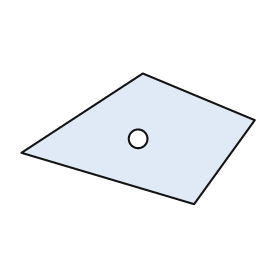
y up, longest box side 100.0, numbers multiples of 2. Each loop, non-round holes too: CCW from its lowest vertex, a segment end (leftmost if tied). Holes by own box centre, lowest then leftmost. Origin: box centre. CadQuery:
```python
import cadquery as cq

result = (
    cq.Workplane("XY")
    .moveTo(24.0, -28.0)
    .lineTo(50.0, 8.0)
    .lineTo(2.0, 28.0)
    .lineTo(-50.0, -6.0)
    .close()
    .moveTo(0.0, 0.0)
    .circle(4.0)
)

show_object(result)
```